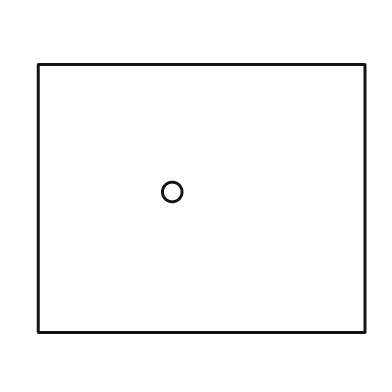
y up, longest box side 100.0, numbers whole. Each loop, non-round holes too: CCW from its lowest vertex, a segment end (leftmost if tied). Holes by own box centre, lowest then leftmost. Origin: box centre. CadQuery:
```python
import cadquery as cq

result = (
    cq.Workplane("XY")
    .moveTo(-50.0, -41.0)
    .lineTo(50.0, -41.0)
    .lineTo(50.0, 41.0)
    .lineTo(-50.0, 41.0)
    .close()
    .moveTo(-9.0, 2.0)
    .circle(3.0)
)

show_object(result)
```